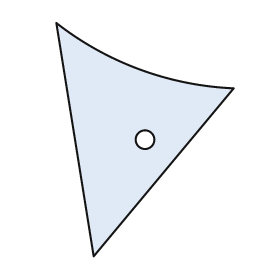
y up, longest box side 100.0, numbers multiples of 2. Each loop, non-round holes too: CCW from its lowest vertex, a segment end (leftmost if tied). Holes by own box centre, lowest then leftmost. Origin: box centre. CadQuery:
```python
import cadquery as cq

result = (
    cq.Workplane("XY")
    .moveTo(-22.0, -50.0)
    .lineTo(38.0, 22.0)
    .threePointArc((-2.0, 30.0), (-38.0, 50.0))
    .close()
    .moveTo(0.0, 0.0)
    .circle(4.0)
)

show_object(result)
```